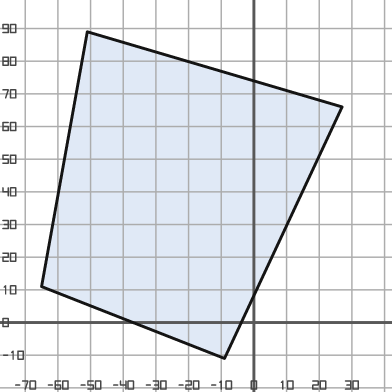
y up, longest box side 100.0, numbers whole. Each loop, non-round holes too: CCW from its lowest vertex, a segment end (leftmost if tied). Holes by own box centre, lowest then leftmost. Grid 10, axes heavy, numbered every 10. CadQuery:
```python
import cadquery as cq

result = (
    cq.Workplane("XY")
    .moveTo(-9.0, -11.0)
    .lineTo(27.0, 66.0)
    .lineTo(-51.0, 89.0)
    .lineTo(-65.0, 11.0)
    .close()
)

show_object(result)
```